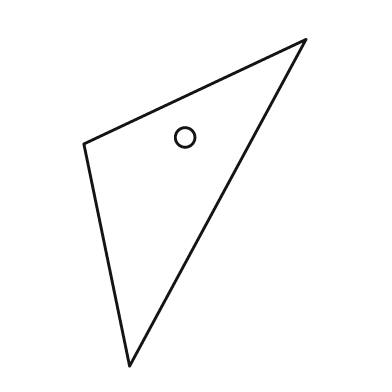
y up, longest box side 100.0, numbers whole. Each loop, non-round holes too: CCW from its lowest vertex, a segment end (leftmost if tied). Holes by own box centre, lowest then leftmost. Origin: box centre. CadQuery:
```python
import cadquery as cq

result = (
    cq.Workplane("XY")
    .moveTo(-20.0, -50.0)
    .lineTo(34.0, 50.0)
    .lineTo(-34.0, 18.0)
    .close()
    .moveTo(-3.0, 20.0)
    .circle(3.0)
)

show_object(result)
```